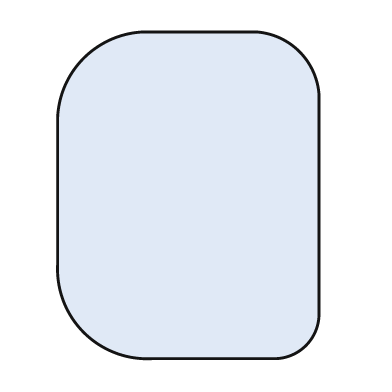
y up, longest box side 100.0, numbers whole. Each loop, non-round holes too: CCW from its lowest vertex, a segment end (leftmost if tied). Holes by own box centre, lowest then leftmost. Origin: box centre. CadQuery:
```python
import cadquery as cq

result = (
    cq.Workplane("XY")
    .moveTo(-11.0, -50.0)
    .lineTo(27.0, -50.0)
    .threePointArc((36.0, -46.0), (40.0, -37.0))
    .lineTo(40.0, 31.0)
    .threePointArc((34.0, 44.0), (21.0, 50.0))
    .lineTo(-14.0, 50.0)
    .threePointArc((-32.0, 42.0), (-40.0, 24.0))
    .lineTo(-40.0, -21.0)
    .threePointArc((-32.0, -42.0), (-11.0, -50.0))
    .close()
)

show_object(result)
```